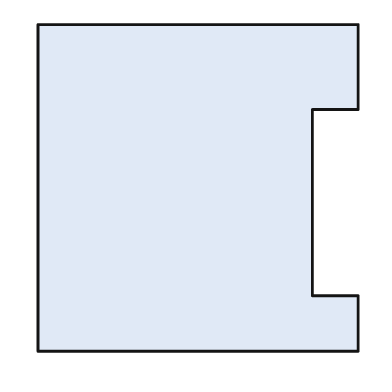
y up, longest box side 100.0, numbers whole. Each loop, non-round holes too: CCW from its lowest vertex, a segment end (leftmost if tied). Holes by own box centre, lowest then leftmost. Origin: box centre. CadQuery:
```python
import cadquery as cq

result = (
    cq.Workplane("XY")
    .moveTo(-49.0, -50.0)
    .lineTo(49.0, -50.0)
    .lineTo(49.0, -33.0)
    .lineTo(35.0, -33.0)
    .lineTo(35.0, 24.0)
    .lineTo(49.0, 24.0)
    .lineTo(49.0, 50.0)
    .lineTo(-49.0, 50.0)
    .close()
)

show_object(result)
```